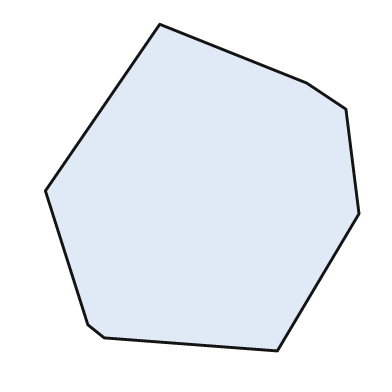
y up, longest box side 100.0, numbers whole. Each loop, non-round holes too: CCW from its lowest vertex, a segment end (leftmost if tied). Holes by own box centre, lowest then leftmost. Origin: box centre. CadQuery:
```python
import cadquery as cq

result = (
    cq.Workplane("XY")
    .moveTo(23.0, -50.0)
    .lineTo(48.0, -8.0)
    .lineTo(44.0, 24.0)
    .lineTo(32.0, 32.0)
    .lineTo(-13.0, 50.0)
    .lineTo(-48.0, -1.0)
    .lineTo(-35.0, -42.0)
    .lineTo(-30.0, -46.0)
    .close()
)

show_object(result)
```